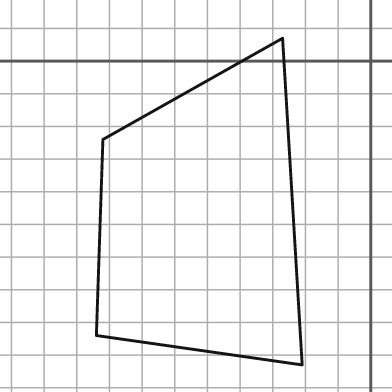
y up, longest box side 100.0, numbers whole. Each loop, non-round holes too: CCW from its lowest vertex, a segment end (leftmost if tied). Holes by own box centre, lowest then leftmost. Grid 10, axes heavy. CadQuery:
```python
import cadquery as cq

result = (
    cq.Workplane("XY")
    .moveTo(-21.0, -93.0)
    .lineTo(-27.0, 7.0)
    .lineTo(-82.0, -24.0)
    .lineTo(-84.0, -84.0)
    .close()
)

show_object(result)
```